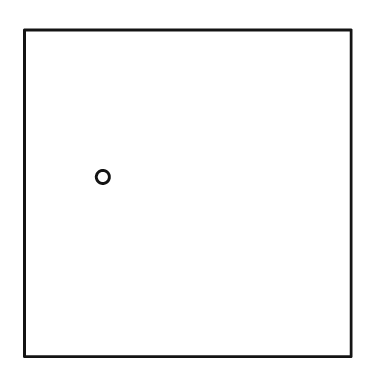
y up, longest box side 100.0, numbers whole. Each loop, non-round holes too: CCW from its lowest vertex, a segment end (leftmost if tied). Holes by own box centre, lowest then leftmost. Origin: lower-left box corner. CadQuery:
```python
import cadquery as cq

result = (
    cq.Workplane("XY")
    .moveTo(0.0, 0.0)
    .lineTo(100.0, 0.0)
    .lineTo(100.0, 100.0)
    .lineTo(0.0, 100.0)
    .close()
    .moveTo(24.0, 55.0)
    .circle(2.0)
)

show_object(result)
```